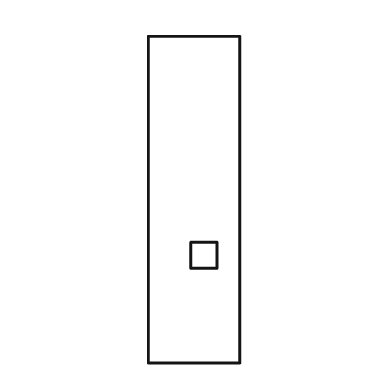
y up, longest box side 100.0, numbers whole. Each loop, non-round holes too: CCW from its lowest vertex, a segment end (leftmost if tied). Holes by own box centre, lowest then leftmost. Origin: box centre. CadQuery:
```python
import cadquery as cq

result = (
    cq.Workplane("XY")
    .moveTo(-14.0, -50.0)
    .lineTo(14.0, -50.0)
    .lineTo(14.0, 50.0)
    .lineTo(-14.0, 50.0)
    .close()
    .moveTo(-1.0, -21.0)
    .lineTo(7.0, -21.0)
    .lineTo(7.0, -13.0)
    .lineTo(-1.0, -13.0)
    .close()
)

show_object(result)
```